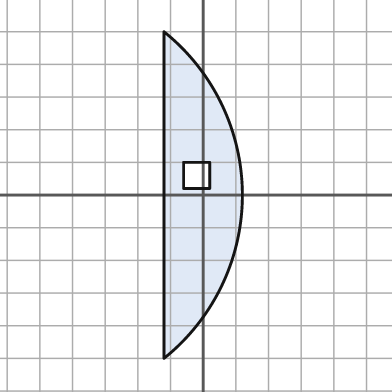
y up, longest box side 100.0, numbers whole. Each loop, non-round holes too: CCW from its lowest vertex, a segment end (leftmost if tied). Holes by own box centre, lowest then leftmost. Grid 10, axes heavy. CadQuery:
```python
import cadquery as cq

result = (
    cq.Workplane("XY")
    .moveTo(-12.0, -50.0)
    .threePointArc((12.0, 0.0), (-12.0, 50.0))
    .close()
    .moveTo(-6.0, 2.0)
    .lineTo(2.0, 2.0)
    .lineTo(2.0, 10.0)
    .lineTo(-6.0, 10.0)
    .close()
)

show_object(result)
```